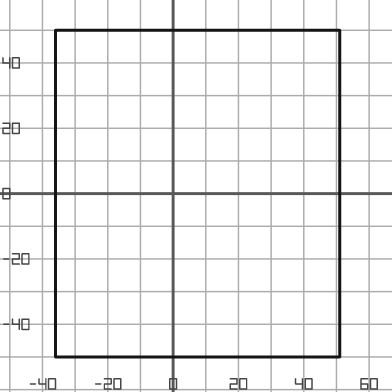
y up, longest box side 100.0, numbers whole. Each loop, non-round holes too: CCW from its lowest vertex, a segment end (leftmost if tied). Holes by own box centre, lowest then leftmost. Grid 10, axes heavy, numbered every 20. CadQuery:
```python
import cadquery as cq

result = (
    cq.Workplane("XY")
    .moveTo(-36.0, -50.0)
    .lineTo(51.0, -50.0)
    .lineTo(51.0, 50.0)
    .lineTo(-36.0, 50.0)
    .close()
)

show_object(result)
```